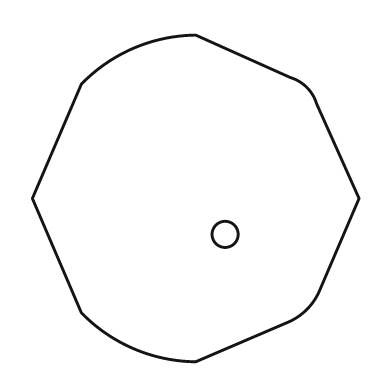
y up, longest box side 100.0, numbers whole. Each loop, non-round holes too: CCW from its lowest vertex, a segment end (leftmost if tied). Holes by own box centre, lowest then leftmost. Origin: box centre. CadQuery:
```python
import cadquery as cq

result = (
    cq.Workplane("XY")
    .moveTo(0.0, -50.0)
    .lineTo(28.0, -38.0)
    .threePointArc((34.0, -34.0), (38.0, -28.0))
    .lineTo(50.0, 0.0)
    .lineTo(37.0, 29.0)
    .threePointArc((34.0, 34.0), (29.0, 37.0))
    .lineTo(0.0, 50.0)
    .threePointArc((-19.0, 46.0), (-35.0, 35.0))
    .lineTo(-50.0, 0.0)
    .lineTo(-35.0, -35.0)
    .threePointArc((-19.0, -46.0), (0.0, -50.0))
    .close()
    .moveTo(9.0, -11.0)
    .circle(4.0)
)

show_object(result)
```